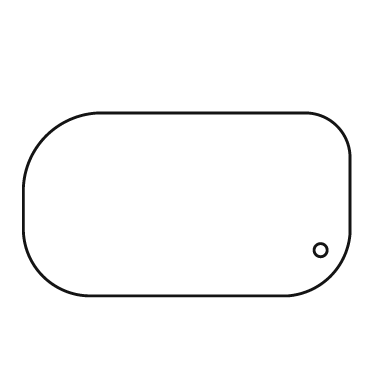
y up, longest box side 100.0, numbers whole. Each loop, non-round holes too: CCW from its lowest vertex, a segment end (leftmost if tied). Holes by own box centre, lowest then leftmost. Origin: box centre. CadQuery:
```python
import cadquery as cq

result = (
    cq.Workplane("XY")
    .moveTo(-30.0, -28.0)
    .lineTo(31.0, -28.0)
    .threePointArc((44.0, -22.0), (50.0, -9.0))
    .lineTo(50.0, 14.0)
    .threePointArc((46.0, 24.0), (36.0, 28.0))
    .lineTo(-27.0, 28.0)
    .threePointArc((-43.0, 21.0), (-50.0, 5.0))
    .lineTo(-50.0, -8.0)
    .threePointArc((-44.0, -22.0), (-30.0, -28.0))
    .close()
    .moveTo(41.0, -14.0)
    .circle(2.0)
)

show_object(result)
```